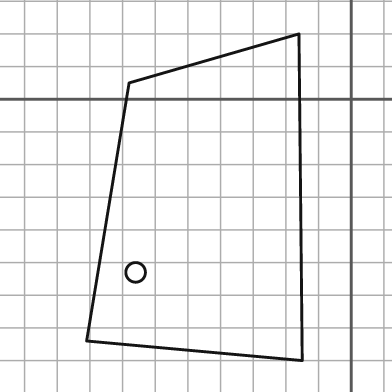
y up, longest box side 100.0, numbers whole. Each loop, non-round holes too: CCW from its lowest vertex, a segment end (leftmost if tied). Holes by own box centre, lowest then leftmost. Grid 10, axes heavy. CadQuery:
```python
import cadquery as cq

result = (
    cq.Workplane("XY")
    .moveTo(-15.0, -80.0)
    .lineTo(-16.0, 20.0)
    .lineTo(-68.0, 5.0)
    .lineTo(-81.0, -74.0)
    .close()
    .moveTo(-66.0, -53.0)
    .circle(3.0)
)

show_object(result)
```